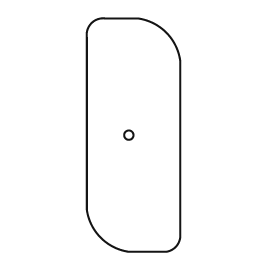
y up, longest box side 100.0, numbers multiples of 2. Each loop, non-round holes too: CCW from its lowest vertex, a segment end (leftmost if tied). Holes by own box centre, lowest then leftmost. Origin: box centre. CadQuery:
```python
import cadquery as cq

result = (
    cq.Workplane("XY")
    .moveTo(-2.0, -50.0)
    .lineTo(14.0, -50.0)
    .threePointArc((18.0, -48.0), (20.0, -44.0))
    .lineTo(20.0, 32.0)
    .threePointArc((14.0, 44.0), (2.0, 50.0))
    .lineTo(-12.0, 50.0)
    .threePointArc((-18.0, 48.0), (-20.0, 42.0))
    .lineTo(-20.0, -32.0)
    .threePointArc((-14.0, -44.0), (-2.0, -50.0))
    .close()
    .moveTo(-2.0, 0.0)
    .circle(2.0)
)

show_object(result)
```